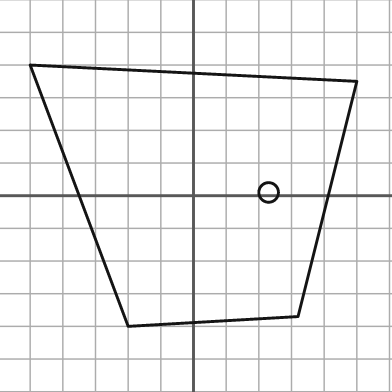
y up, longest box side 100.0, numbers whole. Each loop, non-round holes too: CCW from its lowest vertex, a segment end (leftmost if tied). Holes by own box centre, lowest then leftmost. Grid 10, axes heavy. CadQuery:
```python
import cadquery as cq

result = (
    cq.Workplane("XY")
    .moveTo(-20.0, -40.0)
    .lineTo(32.0, -37.0)
    .lineTo(50.0, 35.0)
    .lineTo(-50.0, 40.0)
    .close()
    .moveTo(23.0, 1.0)
    .circle(3.0)
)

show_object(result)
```